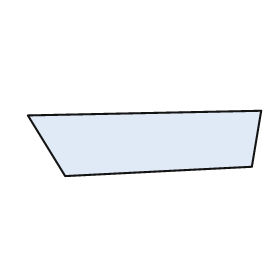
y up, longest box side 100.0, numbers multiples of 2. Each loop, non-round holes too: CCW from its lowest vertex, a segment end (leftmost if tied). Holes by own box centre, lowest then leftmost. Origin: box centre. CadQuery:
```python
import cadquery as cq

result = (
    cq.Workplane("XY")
    .moveTo(-34.0, -14.0)
    .lineTo(46.0, -10.0)
    .lineTo(50.0, 14.0)
    .lineTo(-50.0, 12.0)
    .close()
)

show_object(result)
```